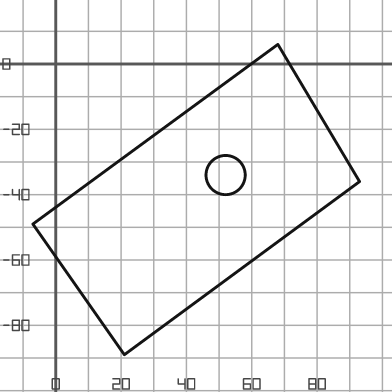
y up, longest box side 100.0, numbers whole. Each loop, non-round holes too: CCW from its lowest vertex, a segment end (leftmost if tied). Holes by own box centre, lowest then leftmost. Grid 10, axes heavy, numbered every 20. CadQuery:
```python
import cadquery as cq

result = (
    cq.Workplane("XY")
    .moveTo(21.0, -89.0)
    .lineTo(93.0, -36.0)
    .lineTo(68.0, 6.0)
    .lineTo(-7.0, -49.0)
    .close()
    .moveTo(52.0, -34.0)
    .circle(6.0)
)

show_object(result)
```